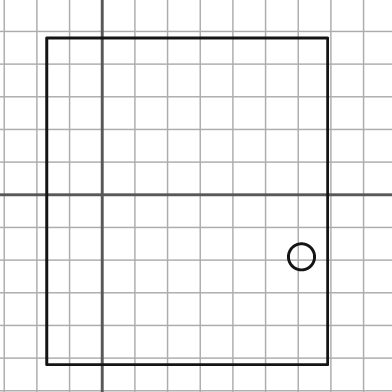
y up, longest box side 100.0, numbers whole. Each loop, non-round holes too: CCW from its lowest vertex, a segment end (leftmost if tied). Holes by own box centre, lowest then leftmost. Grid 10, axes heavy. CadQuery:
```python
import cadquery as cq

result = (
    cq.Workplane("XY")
    .moveTo(-17.0, -52.0)
    .lineTo(69.0, -52.0)
    .lineTo(69.0, 48.0)
    .lineTo(-17.0, 48.0)
    .close()
    .moveTo(61.0, -19.0)
    .circle(4.0)
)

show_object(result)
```